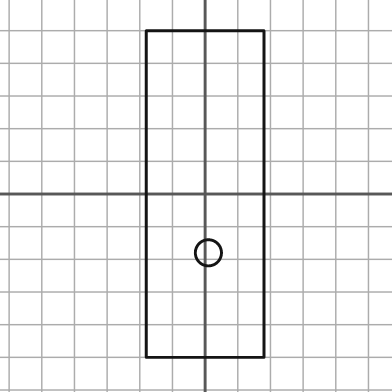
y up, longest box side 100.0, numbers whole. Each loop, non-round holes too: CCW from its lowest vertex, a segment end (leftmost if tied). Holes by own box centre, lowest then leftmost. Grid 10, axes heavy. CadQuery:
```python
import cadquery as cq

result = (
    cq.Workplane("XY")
    .moveTo(-18.0, -50.0)
    .lineTo(18.0, -50.0)
    .lineTo(18.0, 50.0)
    .lineTo(-18.0, 50.0)
    .close()
    .moveTo(1.0, -18.0)
    .circle(4.0)
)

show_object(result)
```